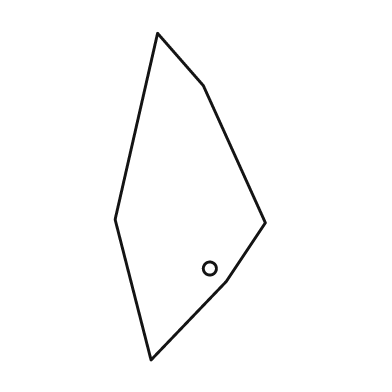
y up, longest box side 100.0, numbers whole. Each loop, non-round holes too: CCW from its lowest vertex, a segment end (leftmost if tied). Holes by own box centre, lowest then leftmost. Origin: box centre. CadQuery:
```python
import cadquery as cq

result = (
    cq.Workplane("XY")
    .moveTo(-12.0, -50.0)
    .lineTo(11.0, -26.0)
    .lineTo(23.0, -8.0)
    .lineTo(4.0, 34.0)
    .lineTo(-10.0, 50.0)
    .lineTo(-23.0, -7.0)
    .close()
    .moveTo(6.0, -22.0)
    .circle(2.0)
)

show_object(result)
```